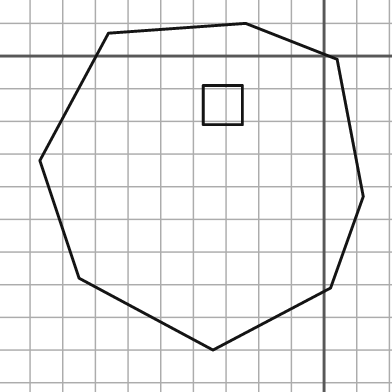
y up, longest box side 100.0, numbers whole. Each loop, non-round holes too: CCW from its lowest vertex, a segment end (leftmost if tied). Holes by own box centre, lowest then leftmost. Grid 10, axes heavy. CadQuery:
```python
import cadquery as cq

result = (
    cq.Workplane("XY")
    .moveTo(-34.0, -90.0)
    .lineTo(2.0, -71.0)
    .lineTo(12.0, -43.0)
    .lineTo(4.0, -1.0)
    .lineTo(-24.0, 10.0)
    .lineTo(-66.0, 7.0)
    .lineTo(-87.0, -32.0)
    .lineTo(-75.0, -68.0)
    .close()
    .moveTo(-37.0, -21.0)
    .lineTo(-25.0, -21.0)
    .lineTo(-25.0, -9.0)
    .lineTo(-37.0, -9.0)
    .close()
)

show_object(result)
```